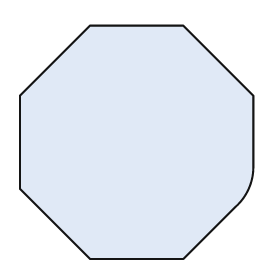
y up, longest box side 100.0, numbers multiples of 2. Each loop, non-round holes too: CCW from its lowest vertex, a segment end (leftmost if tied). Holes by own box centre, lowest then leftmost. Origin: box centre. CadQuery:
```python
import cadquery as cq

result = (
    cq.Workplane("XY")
    .moveTo(-20.0, -50.0)
    .lineTo(20.0, -50.0)
    .lineTo(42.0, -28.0)
    .threePointArc((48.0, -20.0), (50.0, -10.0))
    .lineTo(50.0, 20.0)
    .lineTo(20.0, 50.0)
    .lineTo(-20.0, 50.0)
    .lineTo(-50.0, 20.0)
    .lineTo(-50.0, -20.0)
    .close()
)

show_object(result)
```